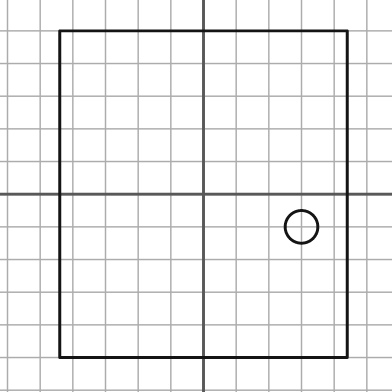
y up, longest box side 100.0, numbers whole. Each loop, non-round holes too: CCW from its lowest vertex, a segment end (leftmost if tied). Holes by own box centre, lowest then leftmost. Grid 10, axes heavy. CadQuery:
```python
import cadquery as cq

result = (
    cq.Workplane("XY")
    .moveTo(-44.0, -50.0)
    .lineTo(44.0, -50.0)
    .lineTo(44.0, 50.0)
    .lineTo(-44.0, 50.0)
    .close()
    .moveTo(30.0, -10.0)
    .circle(5.0)
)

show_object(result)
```